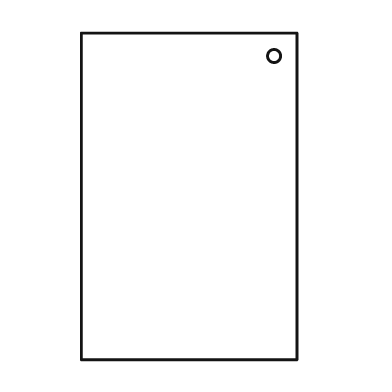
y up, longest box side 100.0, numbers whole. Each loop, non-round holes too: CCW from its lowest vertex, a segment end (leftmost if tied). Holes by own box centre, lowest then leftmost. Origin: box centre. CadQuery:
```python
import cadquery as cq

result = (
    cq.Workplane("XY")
    .moveTo(-33.0, -50.0)
    .lineTo(33.0, -50.0)
    .lineTo(33.0, 50.0)
    .lineTo(-33.0, 50.0)
    .close()
    .moveTo(26.0, 43.0)
    .circle(2.0)
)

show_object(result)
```